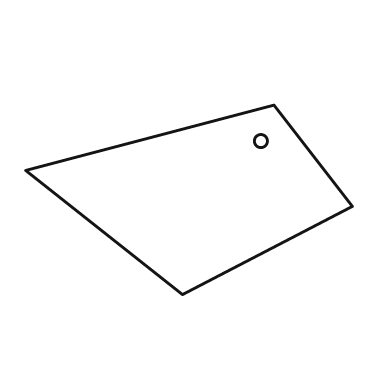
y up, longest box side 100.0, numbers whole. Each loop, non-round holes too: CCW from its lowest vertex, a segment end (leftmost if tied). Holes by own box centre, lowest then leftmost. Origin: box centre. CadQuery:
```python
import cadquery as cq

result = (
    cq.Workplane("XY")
    .moveTo(-2.0, -29.0)
    .lineTo(50.0, -2.0)
    .lineTo(26.0, 29.0)
    .lineTo(-50.0, 9.0)
    .close()
    .moveTo(22.0, 18.0)
    .circle(2.0)
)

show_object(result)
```